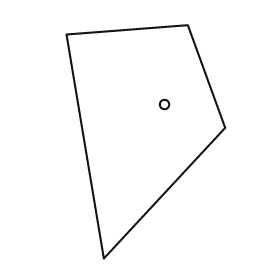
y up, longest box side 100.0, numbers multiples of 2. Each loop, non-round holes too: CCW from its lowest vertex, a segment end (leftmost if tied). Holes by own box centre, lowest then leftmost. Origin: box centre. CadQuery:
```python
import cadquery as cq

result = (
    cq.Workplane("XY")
    .moveTo(-18.0, -50.0)
    .lineTo(34.0, 6.0)
    .lineTo(18.0, 50.0)
    .lineTo(-34.0, 46.0)
    .close()
    .moveTo(8.0, 16.0)
    .circle(2.0)
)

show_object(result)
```